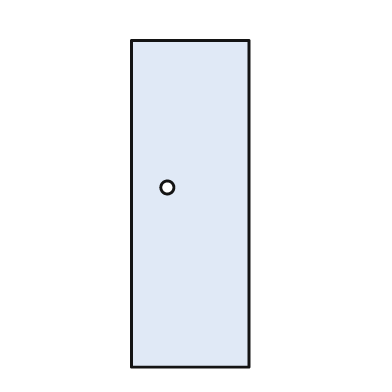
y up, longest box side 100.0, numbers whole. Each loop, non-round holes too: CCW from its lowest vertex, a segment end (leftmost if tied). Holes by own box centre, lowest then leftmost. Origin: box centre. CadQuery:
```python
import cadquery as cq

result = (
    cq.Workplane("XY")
    .moveTo(-18.0, -50.0)
    .lineTo(18.0, -50.0)
    .lineTo(18.0, 50.0)
    .lineTo(-18.0, 50.0)
    .close()
    .moveTo(-7.0, 5.0)
    .circle(2.0)
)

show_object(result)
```